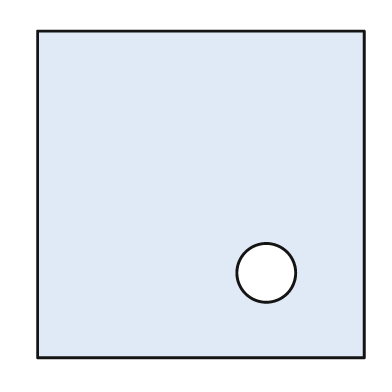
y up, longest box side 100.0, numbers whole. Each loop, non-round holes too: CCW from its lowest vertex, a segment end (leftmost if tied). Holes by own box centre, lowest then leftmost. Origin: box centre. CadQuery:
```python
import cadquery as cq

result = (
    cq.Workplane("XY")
    .moveTo(-50.0, -50.0)
    .lineTo(50.0, -50.0)
    .lineTo(50.0, 50.0)
    .lineTo(-50.0, 50.0)
    .close()
    .moveTo(20.0, -24.0)
    .circle(9.0)
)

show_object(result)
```